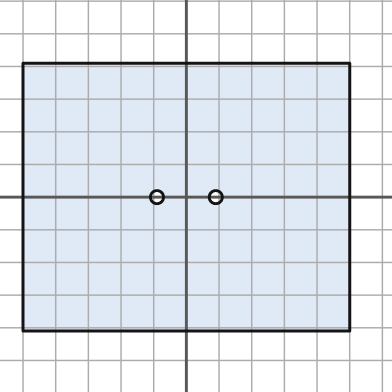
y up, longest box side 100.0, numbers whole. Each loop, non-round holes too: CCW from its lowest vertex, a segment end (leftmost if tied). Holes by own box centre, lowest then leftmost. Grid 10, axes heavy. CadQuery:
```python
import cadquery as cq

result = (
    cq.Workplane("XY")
    .moveTo(-50.0, -41.0)
    .lineTo(50.0, -41.0)
    .lineTo(50.0, 41.0)
    .lineTo(-50.0, 41.0)
    .close()
    .moveTo(-9.0, 0.0)
    .circle(2.0)
    .moveTo(9.0, 0.0)
    .circle(2.0)
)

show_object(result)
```